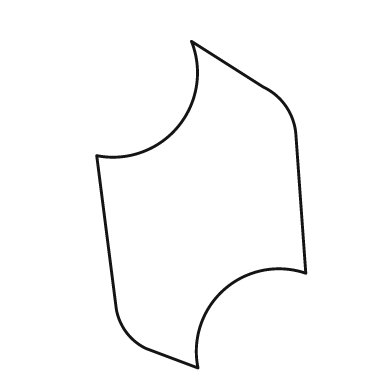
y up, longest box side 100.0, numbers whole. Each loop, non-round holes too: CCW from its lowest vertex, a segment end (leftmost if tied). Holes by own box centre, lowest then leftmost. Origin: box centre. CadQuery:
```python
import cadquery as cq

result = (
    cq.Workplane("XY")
    .moveTo(-1.0, -50.0)
    .threePointArc((7.0, -26.0), (32.0, -21.0))
    .lineTo(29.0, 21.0)
    .threePointArc((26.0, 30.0), (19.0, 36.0))
    .lineTo(-3.0, 50.0)
    .threePointArc((-7.0, 24.0), (-32.0, 15.0))
    .lineTo(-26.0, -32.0)
    .threePointArc((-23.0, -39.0), (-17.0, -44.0))
    .close()
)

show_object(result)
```